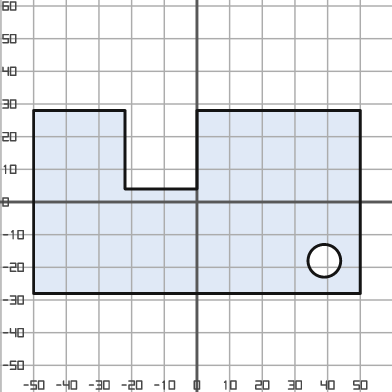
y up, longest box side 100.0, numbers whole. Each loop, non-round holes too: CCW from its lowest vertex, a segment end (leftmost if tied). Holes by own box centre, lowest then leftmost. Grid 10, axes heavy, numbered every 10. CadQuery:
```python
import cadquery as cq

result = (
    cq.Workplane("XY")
    .moveTo(-50.0, -28.0)
    .lineTo(50.0, -28.0)
    .lineTo(50.0, 28.0)
    .lineTo(0.0, 28.0)
    .lineTo(0.0, 4.0)
    .lineTo(-22.0, 4.0)
    .lineTo(-22.0, 28.0)
    .lineTo(-50.0, 28.0)
    .close()
    .moveTo(39.0, -18.0)
    .circle(5.0)
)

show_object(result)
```